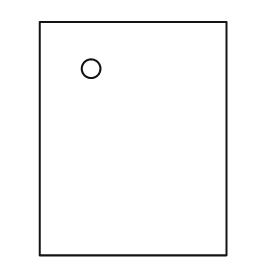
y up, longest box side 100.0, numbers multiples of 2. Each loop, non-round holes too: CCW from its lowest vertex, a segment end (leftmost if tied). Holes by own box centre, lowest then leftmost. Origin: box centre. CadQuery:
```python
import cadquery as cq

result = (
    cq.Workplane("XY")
    .moveTo(-40.0, -50.0)
    .lineTo(40.0, -50.0)
    .lineTo(40.0, 50.0)
    .lineTo(-40.0, 50.0)
    .close()
    .moveTo(-18.0, 30.0)
    .circle(4.0)
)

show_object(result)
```